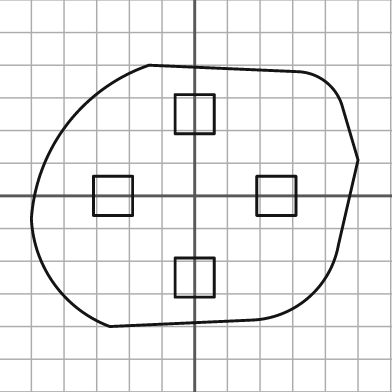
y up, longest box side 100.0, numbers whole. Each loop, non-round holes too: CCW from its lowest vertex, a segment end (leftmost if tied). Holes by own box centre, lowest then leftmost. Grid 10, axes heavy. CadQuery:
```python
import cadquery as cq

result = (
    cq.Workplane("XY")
    .moveTo(-26.0, -40.0)
    .lineTo(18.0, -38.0)
    .threePointArc((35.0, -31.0), (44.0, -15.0))
    .lineTo(50.0, 11.0)
    .lineTo(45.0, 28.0)
    .threePointArc((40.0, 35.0), (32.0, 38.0))
    .lineTo(-14.0, 40.0)
    .threePointArc((-39.0, 22.0), (-50.0, -7.0))
    .threePointArc((-43.0, -27.0), (-26.0, -40.0))
    .close()
    .moveTo(-6.0, -31.0)
    .lineTo(6.0, -31.0)
    .lineTo(6.0, -19.0)
    .lineTo(-6.0, -19.0)
    .close()
    .moveTo(-31.0, -6.0)
    .lineTo(-19.0, -6.0)
    .lineTo(-19.0, 6.0)
    .lineTo(-31.0, 6.0)
    .close()
    .moveTo(19.0, -6.0)
    .lineTo(31.0, -6.0)
    .lineTo(31.0, 6.0)
    .lineTo(19.0, 6.0)
    .close()
    .moveTo(-6.0, 19.0)
    .lineTo(6.0, 19.0)
    .lineTo(6.0, 31.0)
    .lineTo(-6.0, 31.0)
    .close()
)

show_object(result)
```